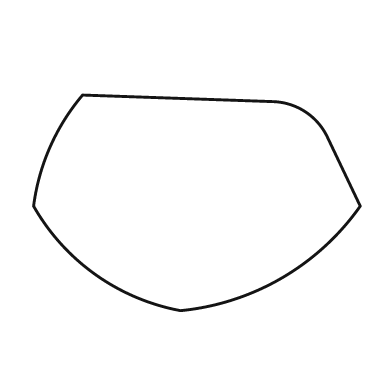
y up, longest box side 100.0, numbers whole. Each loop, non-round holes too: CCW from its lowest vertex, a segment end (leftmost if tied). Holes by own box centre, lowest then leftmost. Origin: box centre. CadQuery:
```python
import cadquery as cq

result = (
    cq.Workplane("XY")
    .moveTo(-5.0, -33.0)
    .threePointArc((26.0, -23.0), (50.0, -1.0))
    .lineTo(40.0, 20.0)
    .threePointArc((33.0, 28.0), (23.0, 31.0))
    .lineTo(-35.0, 33.0)
    .threePointArc((-45.0, 17.0), (-50.0, -1.0))
    .threePointArc((-31.0, -22.0), (-5.0, -33.0))
    .close()
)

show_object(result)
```